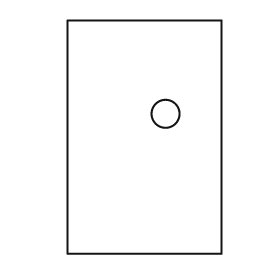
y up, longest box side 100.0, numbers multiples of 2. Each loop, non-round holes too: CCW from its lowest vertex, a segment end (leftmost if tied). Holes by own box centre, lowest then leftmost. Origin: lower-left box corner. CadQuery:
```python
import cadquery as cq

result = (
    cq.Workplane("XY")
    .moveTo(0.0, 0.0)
    .lineTo(66.0, 0.0)
    .lineTo(66.0, 100.0)
    .lineTo(0.0, 100.0)
    .close()
    .moveTo(42.0, 60.0)
    .circle(6.0)
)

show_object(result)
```